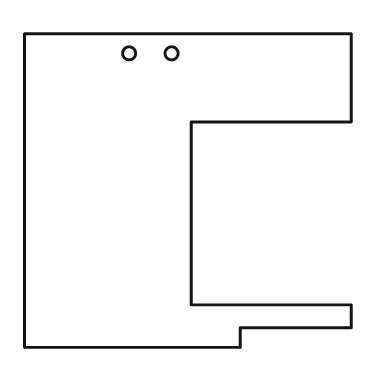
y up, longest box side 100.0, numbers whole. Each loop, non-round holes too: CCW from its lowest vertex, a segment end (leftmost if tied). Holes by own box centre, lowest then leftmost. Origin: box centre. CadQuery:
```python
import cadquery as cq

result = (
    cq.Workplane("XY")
    .moveTo(-50.0, -48.0)
    .lineTo(16.0, -48.0)
    .lineTo(16.0, -42.0)
    .lineTo(50.0, -42.0)
    .lineTo(50.0, -35.0)
    .lineTo(1.0, -35.0)
    .lineTo(1.0, 21.0)
    .lineTo(50.0, 21.0)
    .lineTo(50.0, 48.0)
    .lineTo(-50.0, 48.0)
    .close()
    .moveTo(-18.0, 42.0)
    .circle(2.0)
    .moveTo(-5.0, 42.0)
    .circle(2.0)
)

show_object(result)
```